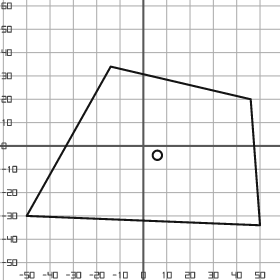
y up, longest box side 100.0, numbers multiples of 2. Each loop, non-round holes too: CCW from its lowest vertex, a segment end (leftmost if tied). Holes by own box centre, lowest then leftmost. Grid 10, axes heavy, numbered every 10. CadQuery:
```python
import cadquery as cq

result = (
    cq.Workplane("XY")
    .moveTo(50.0, -34.0)
    .lineTo(46.0, 20.0)
    .lineTo(-14.0, 34.0)
    .lineTo(-50.0, -30.0)
    .close()
    .moveTo(6.0, -4.0)
    .circle(2.0)
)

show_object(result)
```